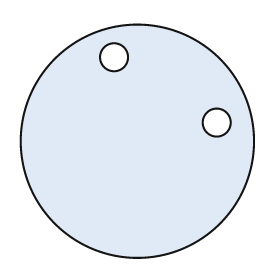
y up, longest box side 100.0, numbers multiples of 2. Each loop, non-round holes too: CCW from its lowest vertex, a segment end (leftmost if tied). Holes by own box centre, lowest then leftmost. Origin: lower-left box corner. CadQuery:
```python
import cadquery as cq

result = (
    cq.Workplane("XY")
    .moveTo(50.0, 50.0)
    .circle(50.0)
    .moveTo(84.0, 58.0)
    .circle(6.0)
    .moveTo(40.0, 86.0)
    .circle(6.0)
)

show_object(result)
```